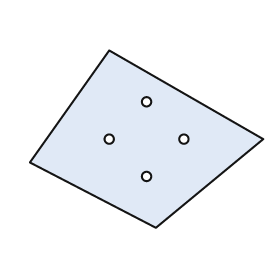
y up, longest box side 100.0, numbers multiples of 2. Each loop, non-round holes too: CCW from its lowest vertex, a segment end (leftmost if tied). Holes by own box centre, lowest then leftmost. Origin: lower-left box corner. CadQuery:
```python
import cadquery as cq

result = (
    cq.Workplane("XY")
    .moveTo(54.0, 0.0)
    .lineTo(100.0, 38.0)
    .lineTo(34.0, 76.0)
    .lineTo(0.0, 28.0)
    .close()
    .moveTo(50.0, 22.0)
    .circle(2.0)
    .moveTo(34.0, 38.0)
    .circle(2.0)
    .moveTo(66.0, 38.0)
    .circle(2.0)
    .moveTo(50.0, 54.0)
    .circle(2.0)
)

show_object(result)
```